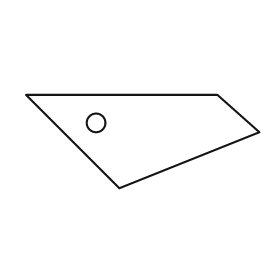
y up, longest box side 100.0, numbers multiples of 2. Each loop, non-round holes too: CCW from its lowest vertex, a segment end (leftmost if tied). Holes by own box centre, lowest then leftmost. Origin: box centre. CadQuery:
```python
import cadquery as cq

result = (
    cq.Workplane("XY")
    .moveTo(-10.0, -20.0)
    .lineTo(50.0, 4.0)
    .lineTo(32.0, 20.0)
    .lineTo(-50.0, 20.0)
    .close()
    .moveTo(-20.0, 8.0)
    .circle(4.0)
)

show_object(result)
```